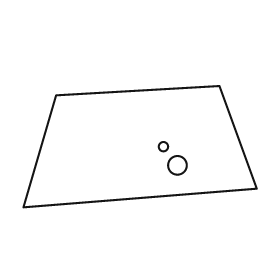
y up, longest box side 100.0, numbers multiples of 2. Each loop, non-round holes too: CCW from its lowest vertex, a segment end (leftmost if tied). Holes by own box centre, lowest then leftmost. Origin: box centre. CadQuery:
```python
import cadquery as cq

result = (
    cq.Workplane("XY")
    .moveTo(-50.0, -26.0)
    .lineTo(50.0, -18.0)
    .lineTo(34.0, 26.0)
    .lineTo(-36.0, 22.0)
    .close()
    .moveTo(16.0, -8.0)
    .circle(4.0)
    .moveTo(10.0, 0.0)
    .circle(2.0)
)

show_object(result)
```